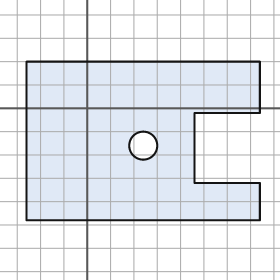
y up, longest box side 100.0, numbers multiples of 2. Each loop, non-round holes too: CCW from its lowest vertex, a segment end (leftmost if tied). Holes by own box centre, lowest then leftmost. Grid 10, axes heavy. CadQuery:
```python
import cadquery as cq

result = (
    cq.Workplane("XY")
    .moveTo(-26.0, -48.0)
    .lineTo(74.0, -48.0)
    .lineTo(74.0, -32.0)
    .lineTo(46.0, -32.0)
    .lineTo(46.0, -2.0)
    .lineTo(74.0, -2.0)
    .lineTo(74.0, 20.0)
    .lineTo(-26.0, 20.0)
    .close()
    .moveTo(24.0, -16.0)
    .circle(6.0)
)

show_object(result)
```